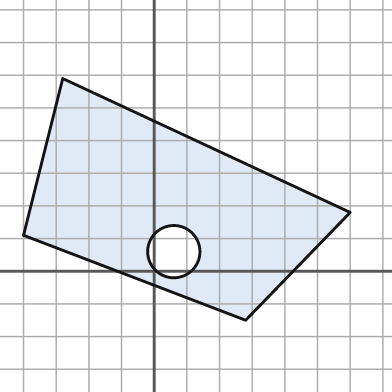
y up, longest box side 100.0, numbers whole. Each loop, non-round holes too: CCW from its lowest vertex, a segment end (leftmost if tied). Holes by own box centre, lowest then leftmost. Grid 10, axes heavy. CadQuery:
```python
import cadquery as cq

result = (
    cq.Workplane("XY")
    .moveTo(28.0, -15.0)
    .lineTo(60.0, 18.0)
    .lineTo(-28.0, 59.0)
    .lineTo(-40.0, 11.0)
    .close()
    .moveTo(6.0, 6.0)
    .circle(8.0)
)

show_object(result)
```